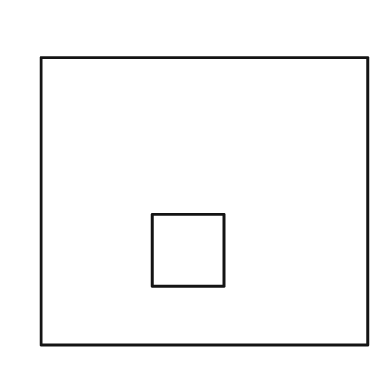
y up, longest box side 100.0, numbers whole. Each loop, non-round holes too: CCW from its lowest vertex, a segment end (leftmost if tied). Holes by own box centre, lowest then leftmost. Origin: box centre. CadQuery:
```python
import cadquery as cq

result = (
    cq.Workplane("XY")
    .moveTo(-50.0, -44.0)
    .lineTo(50.0, -44.0)
    .lineTo(50.0, 44.0)
    .lineTo(-50.0, 44.0)
    .close()
    .moveTo(-16.0, -26.0)
    .lineTo(6.0, -26.0)
    .lineTo(6.0, -4.0)
    .lineTo(-16.0, -4.0)
    .close()
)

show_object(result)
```